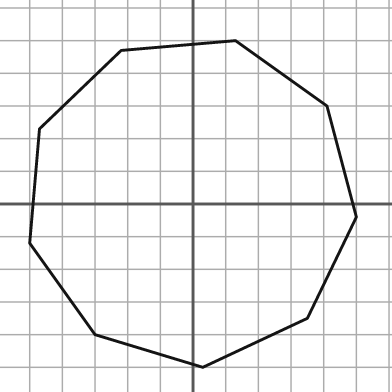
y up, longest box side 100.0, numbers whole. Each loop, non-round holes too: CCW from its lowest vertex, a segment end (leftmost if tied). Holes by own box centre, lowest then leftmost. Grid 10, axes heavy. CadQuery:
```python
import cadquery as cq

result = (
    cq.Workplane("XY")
    .moveTo(3.0, -50.0)
    .lineTo(35.0, -35.0)
    .lineTo(50.0, -4.0)
    .lineTo(41.0, 30.0)
    .lineTo(13.0, 50.0)
    .lineTo(-22.0, 47.0)
    .lineTo(-47.0, 23.0)
    .lineTo(-50.0, -12.0)
    .lineTo(-30.0, -40.0)
    .close()
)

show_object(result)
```